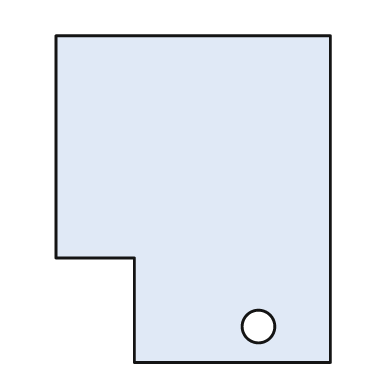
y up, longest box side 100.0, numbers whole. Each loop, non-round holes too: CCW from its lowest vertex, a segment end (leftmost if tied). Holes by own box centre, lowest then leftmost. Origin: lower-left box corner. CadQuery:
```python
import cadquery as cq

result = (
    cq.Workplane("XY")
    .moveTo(24.0, 0.0)
    .lineTo(84.0, 0.0)
    .lineTo(84.0, 100.0)
    .lineTo(0.0, 100.0)
    .lineTo(0.0, 32.0)
    .lineTo(24.0, 32.0)
    .close()
    .moveTo(62.0, 11.0)
    .circle(5.0)
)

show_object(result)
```